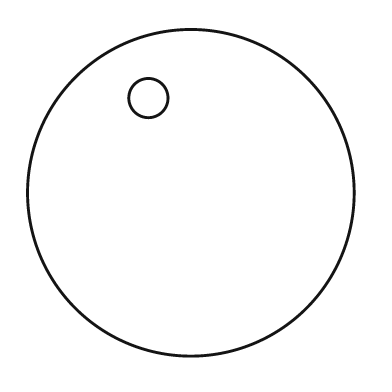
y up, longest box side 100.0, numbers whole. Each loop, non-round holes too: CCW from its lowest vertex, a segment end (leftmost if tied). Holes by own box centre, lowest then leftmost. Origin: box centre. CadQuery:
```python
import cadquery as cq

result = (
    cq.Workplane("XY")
    .moveTo(0.0, 0.0)
    .circle(50.0)
    .moveTo(-13.0, 29.0)
    .circle(6.0)
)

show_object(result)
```